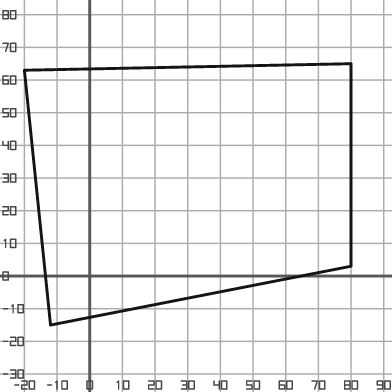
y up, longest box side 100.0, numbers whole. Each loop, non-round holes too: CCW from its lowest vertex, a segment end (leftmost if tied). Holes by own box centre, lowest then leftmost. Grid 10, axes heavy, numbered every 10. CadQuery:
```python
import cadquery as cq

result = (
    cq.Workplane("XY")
    .moveTo(-12.0, -15.0)
    .lineTo(80.0, 3.0)
    .lineTo(80.0, 65.0)
    .lineTo(-20.0, 63.0)
    .close()
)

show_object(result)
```